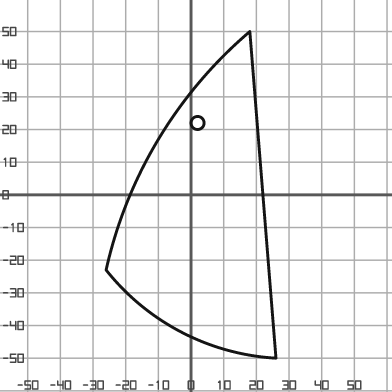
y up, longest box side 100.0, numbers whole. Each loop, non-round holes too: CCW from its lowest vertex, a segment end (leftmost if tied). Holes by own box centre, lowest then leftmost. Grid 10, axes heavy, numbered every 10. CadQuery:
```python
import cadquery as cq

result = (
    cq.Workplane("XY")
    .moveTo(26.0, -50.0)
    .lineTo(18.0, 50.0)
    .threePointArc((-10.0, 17.0), (-26.0, -23.0))
    .threePointArc((-3.0, -42.0), (26.0, -50.0))
    .close()
    .moveTo(2.0, 22.0)
    .circle(2.0)
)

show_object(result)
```